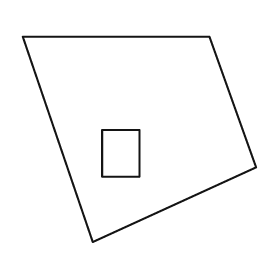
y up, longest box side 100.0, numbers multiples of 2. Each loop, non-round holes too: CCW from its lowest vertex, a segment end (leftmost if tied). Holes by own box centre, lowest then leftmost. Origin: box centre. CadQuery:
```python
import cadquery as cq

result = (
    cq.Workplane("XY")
    .moveTo(-20.0, -44.0)
    .lineTo(50.0, -12.0)
    .lineTo(30.0, 44.0)
    .lineTo(-50.0, 44.0)
    .close()
    .moveTo(-16.0, -16.0)
    .lineTo(0.0, -16.0)
    .lineTo(0.0, 4.0)
    .lineTo(-16.0, 4.0)
    .close()
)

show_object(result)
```